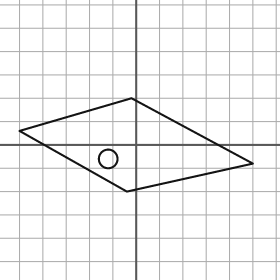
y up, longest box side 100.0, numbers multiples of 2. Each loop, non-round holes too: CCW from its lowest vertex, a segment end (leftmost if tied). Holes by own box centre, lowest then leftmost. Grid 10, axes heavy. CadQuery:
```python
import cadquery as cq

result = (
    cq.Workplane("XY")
    .moveTo(-4.0, -20.0)
    .lineTo(50.0, -8.0)
    .lineTo(-2.0, 20.0)
    .lineTo(-50.0, 6.0)
    .close()
    .moveTo(-12.0, -6.0)
    .circle(4.0)
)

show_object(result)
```